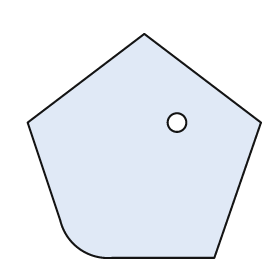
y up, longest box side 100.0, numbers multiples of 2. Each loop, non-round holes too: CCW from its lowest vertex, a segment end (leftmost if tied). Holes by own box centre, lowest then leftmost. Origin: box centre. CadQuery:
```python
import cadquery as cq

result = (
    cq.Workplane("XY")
    .moveTo(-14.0, -48.0)
    .lineTo(30.0, -48.0)
    .lineTo(50.0, 10.0)
    .lineTo(0.0, 48.0)
    .lineTo(-50.0, 10.0)
    .lineTo(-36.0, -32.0)
    .threePointArc((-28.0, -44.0), (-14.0, -48.0))
    .close()
    .moveTo(14.0, 10.0)
    .circle(4.0)
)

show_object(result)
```